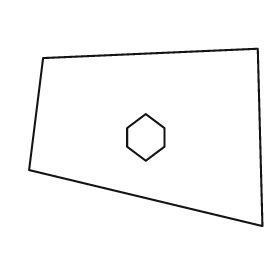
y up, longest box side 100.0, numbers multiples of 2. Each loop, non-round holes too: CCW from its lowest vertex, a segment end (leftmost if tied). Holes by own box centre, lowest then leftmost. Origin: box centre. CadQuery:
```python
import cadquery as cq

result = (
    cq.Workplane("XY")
    .moveTo(50.0, -38.0)
    .lineTo(48.0, 38.0)
    .lineTo(-44.0, 34.0)
    .lineTo(-50.0, -14.0)
    .close()
    .moveTo(0.0, -10.0)
    .lineTo(8.0, -4.0)
    .lineTo(8.0, 4.0)
    .lineTo(0.0, 10.0)
    .lineTo(-8.0, 4.0)
    .lineTo(-8.0, -4.0)
    .close()
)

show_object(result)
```